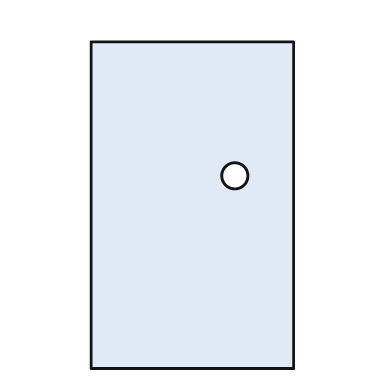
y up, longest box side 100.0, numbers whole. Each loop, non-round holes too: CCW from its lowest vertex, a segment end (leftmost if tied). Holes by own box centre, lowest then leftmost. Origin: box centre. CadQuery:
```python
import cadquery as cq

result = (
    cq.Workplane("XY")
    .moveTo(-31.0, -50.0)
    .lineTo(31.0, -50.0)
    .lineTo(31.0, 50.0)
    .lineTo(-31.0, 50.0)
    .close()
    .moveTo(13.0, 9.0)
    .circle(4.0)
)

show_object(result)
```